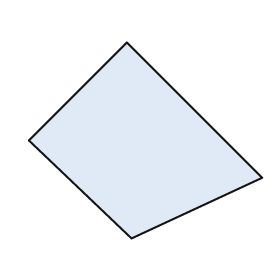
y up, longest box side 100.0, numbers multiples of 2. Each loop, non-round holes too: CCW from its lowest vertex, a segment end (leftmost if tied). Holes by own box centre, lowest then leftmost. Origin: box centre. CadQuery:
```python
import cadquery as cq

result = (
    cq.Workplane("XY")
    .moveTo(-6.0, -42.0)
    .lineTo(50.0, -16.0)
    .lineTo(-8.0, 42.0)
    .lineTo(-50.0, 0.0)
    .close()
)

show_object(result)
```